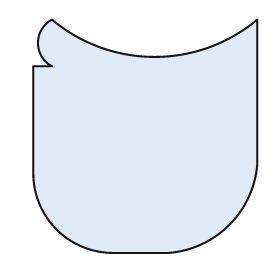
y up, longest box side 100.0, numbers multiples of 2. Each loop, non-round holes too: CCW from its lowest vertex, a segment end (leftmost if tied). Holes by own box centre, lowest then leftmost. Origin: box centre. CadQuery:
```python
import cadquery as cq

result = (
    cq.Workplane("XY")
    .moveTo(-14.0, -50.0)
    .lineTo(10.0, -50.0)
    .threePointArc((36.0, -38.0), (48.0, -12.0))
    .lineTo(48.0, 50.0)
    .threePointArc((4.0, 34.0), (-40.0, 50.0))
    .threePointArc((-46.0, 40.0), (-40.0, 30.0))
    .lineTo(-48.0, 30.0)
    .lineTo(-48.0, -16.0)
    .threePointArc((-38.0, -40.0), (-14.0, -50.0))
    .close()
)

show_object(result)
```